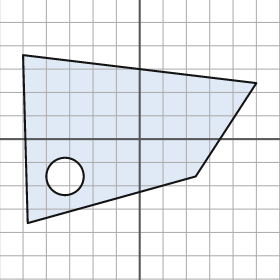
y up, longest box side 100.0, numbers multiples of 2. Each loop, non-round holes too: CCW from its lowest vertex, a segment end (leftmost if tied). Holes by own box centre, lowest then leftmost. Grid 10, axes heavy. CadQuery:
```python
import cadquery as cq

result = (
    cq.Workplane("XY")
    .moveTo(-48.0, -36.0)
    .lineTo(24.0, -16.0)
    .lineTo(50.0, 24.0)
    .lineTo(-50.0, 36.0)
    .close()
    .moveTo(-32.0, -16.0)
    .circle(8.0)
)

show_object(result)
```